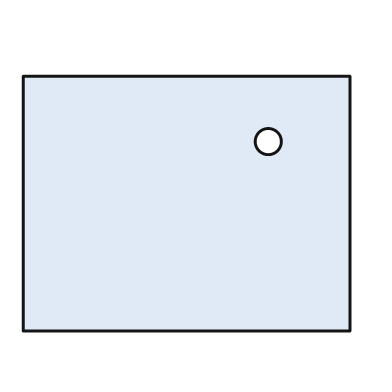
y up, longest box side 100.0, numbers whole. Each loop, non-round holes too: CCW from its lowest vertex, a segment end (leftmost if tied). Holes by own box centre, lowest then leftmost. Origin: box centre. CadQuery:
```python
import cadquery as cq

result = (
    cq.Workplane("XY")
    .moveTo(-50.0, -39.0)
    .lineTo(50.0, -39.0)
    .lineTo(50.0, 39.0)
    .lineTo(-50.0, 39.0)
    .close()
    .moveTo(25.0, 19.0)
    .circle(4.0)
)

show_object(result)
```